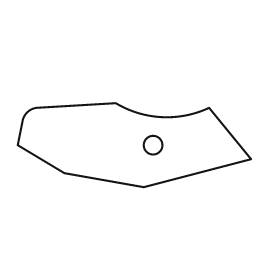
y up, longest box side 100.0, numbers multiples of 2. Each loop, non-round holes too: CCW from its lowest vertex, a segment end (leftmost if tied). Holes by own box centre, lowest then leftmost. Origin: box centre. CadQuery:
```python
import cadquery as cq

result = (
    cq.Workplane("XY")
    .moveTo(4.0, -18.0)
    .lineTo(50.0, -6.0)
    .lineTo(32.0, 16.0)
    .threePointArc((12.0, 12.0), (-8.0, 18.0))
    .lineTo(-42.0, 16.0)
    .threePointArc((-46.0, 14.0), (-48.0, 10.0))
    .lineTo(-50.0, 0.0)
    .lineTo(-30.0, -12.0)
    .close()
    .moveTo(8.0, 0.0)
    .circle(4.0)
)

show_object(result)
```